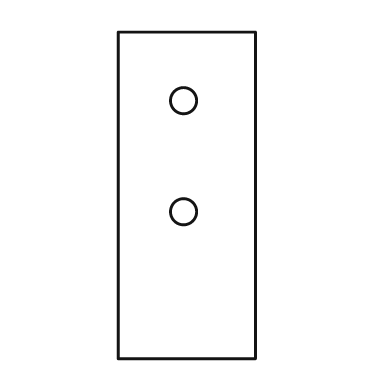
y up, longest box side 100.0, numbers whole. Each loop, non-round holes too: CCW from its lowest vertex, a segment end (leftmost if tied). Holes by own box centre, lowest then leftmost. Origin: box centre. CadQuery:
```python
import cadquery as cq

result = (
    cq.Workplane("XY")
    .moveTo(-21.0, -50.0)
    .lineTo(21.0, -50.0)
    .lineTo(21.0, 50.0)
    .lineTo(-21.0, 50.0)
    .close()
    .moveTo(-1.0, -5.0)
    .circle(4.0)
    .moveTo(-1.0, 29.0)
    .circle(4.0)
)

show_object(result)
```